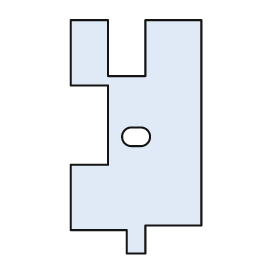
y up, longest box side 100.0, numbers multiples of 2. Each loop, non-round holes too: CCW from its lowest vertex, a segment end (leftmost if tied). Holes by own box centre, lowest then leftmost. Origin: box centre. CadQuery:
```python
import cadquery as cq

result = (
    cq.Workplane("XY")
    .moveTo(-4.0, -50.0)
    .lineTo(4.0, -50.0)
    .lineTo(4.0, -38.0)
    .lineTo(28.0, -38.0)
    .lineTo(28.0, 50.0)
    .lineTo(4.0, 50.0)
    .lineTo(4.0, 26.0)
    .lineTo(-12.0, 26.0)
    .lineTo(-12.0, 50.0)
    .lineTo(-28.0, 50.0)
    .lineTo(-28.0, 22.0)
    .lineTo(-12.0, 22.0)
    .lineTo(-12.0, -12.0)
    .lineTo(-28.0, -12.0)
    .lineTo(-28.0, -40.0)
    .lineTo(-4.0, -40.0)
    .close()
    .moveTo(-2.0, -4.0)
    .lineTo(2.0, -4.0)
    .threePointArc((6.0, 0.0), (2.0, 4.0))
    .lineTo(-2.0, 4.0)
    .threePointArc((-6.0, 0.0), (-2.0, -4.0))
    .close()
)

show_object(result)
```